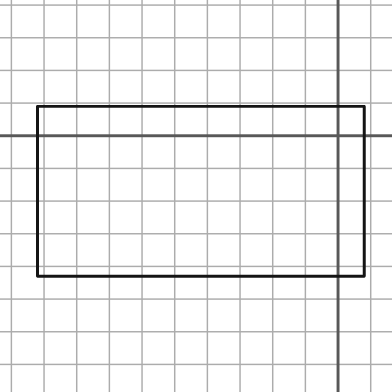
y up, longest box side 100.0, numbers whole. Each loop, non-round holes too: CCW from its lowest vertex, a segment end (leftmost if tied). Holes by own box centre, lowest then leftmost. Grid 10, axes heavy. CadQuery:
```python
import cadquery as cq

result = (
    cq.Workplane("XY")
    .moveTo(-92.0, -43.0)
    .lineTo(8.0, -43.0)
    .lineTo(8.0, 9.0)
    .lineTo(-92.0, 9.0)
    .close()
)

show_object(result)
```